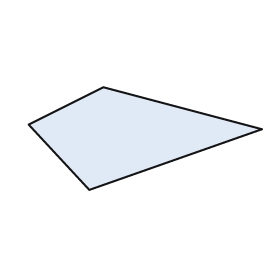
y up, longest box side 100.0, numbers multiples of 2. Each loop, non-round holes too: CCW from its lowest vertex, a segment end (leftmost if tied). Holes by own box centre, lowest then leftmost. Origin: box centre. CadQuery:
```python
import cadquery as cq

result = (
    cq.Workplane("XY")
    .moveTo(-24.0, -22.0)
    .lineTo(50.0, 4.0)
    .lineTo(-18.0, 22.0)
    .lineTo(-50.0, 6.0)
    .close()
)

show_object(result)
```